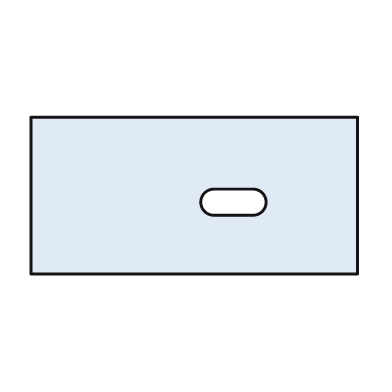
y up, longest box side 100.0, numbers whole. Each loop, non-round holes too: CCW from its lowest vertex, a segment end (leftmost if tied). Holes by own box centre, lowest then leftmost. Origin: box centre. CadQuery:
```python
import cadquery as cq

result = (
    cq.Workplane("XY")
    .moveTo(-50.0, -24.0)
    .lineTo(50.0, -24.0)
    .lineTo(50.0, 24.0)
    .lineTo(-50.0, 24.0)
    .close()
    .moveTo(6.0, -6.0)
    .lineTo(18.0, -6.0)
    .threePointArc((22.0, -2.0), (18.0, 2.0))
    .lineTo(6.0, 2.0)
    .threePointArc((2.0, -2.0), (6.0, -6.0))
    .close()
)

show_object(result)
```